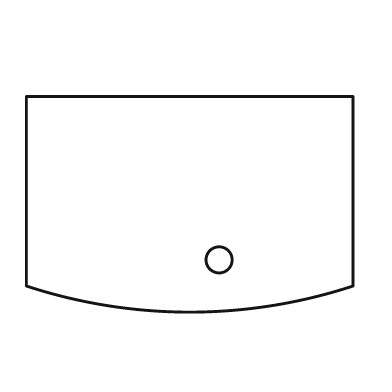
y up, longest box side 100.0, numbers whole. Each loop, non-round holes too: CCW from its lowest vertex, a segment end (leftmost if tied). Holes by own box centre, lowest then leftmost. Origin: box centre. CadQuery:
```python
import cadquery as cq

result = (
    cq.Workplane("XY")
    .moveTo(-50.0, -25.0)
    .threePointArc((0.0, -33.0), (50.0, -25.0))
    .lineTo(50.0, 33.0)
    .lineTo(-50.0, 33.0)
    .close()
    .moveTo(9.0, -17.0)
    .circle(4.0)
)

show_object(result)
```